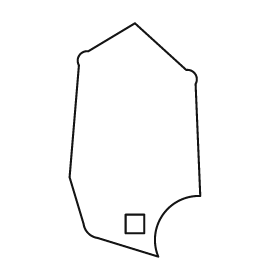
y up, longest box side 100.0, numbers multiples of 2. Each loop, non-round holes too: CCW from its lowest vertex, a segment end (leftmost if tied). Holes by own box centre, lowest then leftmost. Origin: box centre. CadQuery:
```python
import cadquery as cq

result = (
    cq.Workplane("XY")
    .moveTo(10.0, -50.0)
    .threePointArc((12.0, -32.0), (28.0, -24.0))
    .lineTo(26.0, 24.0)
    .threePointArc((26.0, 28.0), (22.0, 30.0))
    .lineTo(0.0, 50.0)
    .lineTo(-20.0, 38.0)
    .threePointArc((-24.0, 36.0), (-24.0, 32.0))
    .lineTo(-28.0, -16.0)
    .lineTo(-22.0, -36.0)
    .threePointArc((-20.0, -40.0), (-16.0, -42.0))
    .close()
    .moveTo(-4.0, -40.0)
    .lineTo(4.0, -40.0)
    .lineTo(4.0, -32.0)
    .lineTo(-4.0, -32.0)
    .close()
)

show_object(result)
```